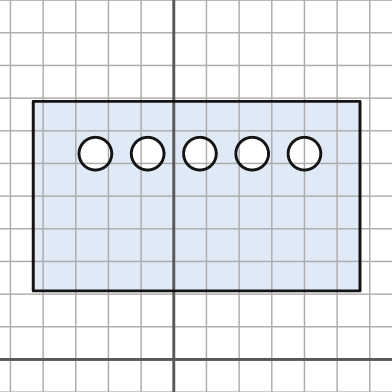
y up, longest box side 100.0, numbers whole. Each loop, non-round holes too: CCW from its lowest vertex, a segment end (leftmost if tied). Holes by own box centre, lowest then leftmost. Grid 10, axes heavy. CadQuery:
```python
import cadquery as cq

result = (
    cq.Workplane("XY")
    .moveTo(-43.0, 21.0)
    .lineTo(57.0, 21.0)
    .lineTo(57.0, 79.0)
    .lineTo(-43.0, 79.0)
    .close()
    .moveTo(-24.0, 63.0)
    .circle(5.0)
    .moveTo(-8.0, 63.0)
    .circle(5.0)
    .moveTo(8.0, 63.0)
    .circle(5.0)
    .moveTo(24.0, 63.0)
    .circle(5.0)
    .moveTo(40.0, 63.0)
    .circle(5.0)
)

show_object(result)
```